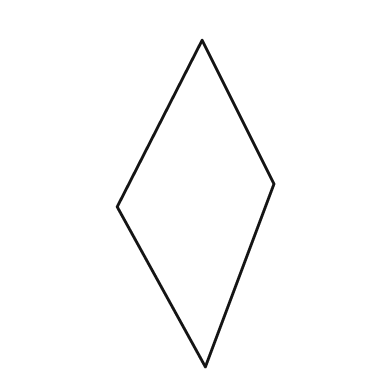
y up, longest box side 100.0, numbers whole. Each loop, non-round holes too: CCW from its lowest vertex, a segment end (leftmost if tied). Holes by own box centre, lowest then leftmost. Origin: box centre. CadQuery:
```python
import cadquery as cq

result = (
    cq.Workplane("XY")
    .moveTo(3.0, -50.0)
    .lineTo(24.0, 6.0)
    .lineTo(2.0, 50.0)
    .lineTo(-24.0, -1.0)
    .close()
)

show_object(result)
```